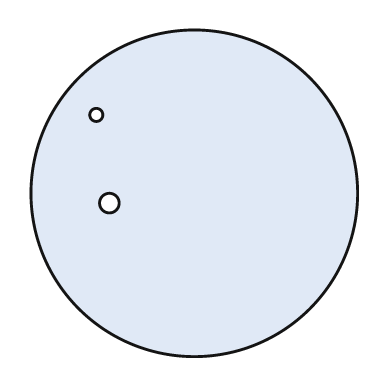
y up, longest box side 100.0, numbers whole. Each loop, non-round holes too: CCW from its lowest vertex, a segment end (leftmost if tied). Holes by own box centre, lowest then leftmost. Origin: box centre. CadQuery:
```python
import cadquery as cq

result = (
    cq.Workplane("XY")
    .moveTo(0.0, 0.0)
    .circle(50.0)
    .moveTo(-26.0, -3.0)
    .circle(3.0)
    .moveTo(-30.0, 24.0)
    .circle(2.0)
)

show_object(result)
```